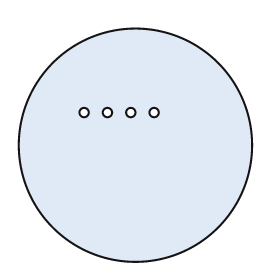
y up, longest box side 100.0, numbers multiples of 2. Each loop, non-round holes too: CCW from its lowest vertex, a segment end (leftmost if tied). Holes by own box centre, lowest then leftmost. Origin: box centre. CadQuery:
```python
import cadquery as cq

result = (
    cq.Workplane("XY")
    .moveTo(0.0, 0.0)
    .circle(50.0)
    .moveTo(-22.0, 14.0)
    .circle(2.0)
    .moveTo(-12.0, 14.0)
    .circle(2.0)
    .moveTo(-2.0, 14.0)
    .circle(2.0)
    .moveTo(8.0, 14.0)
    .circle(2.0)
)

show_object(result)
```